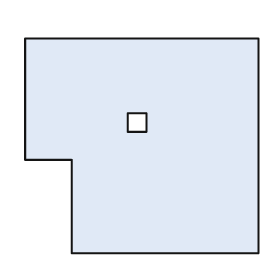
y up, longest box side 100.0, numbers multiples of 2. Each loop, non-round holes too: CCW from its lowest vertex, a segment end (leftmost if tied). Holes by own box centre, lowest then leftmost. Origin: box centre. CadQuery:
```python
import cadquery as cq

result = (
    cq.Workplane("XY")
    .moveTo(-30.0, -46.0)
    .lineTo(50.0, -46.0)
    .lineTo(50.0, 46.0)
    .lineTo(-50.0, 46.0)
    .lineTo(-50.0, -6.0)
    .lineTo(-30.0, -6.0)
    .close()
    .moveTo(-6.0, 6.0)
    .lineTo(2.0, 6.0)
    .lineTo(2.0, 14.0)
    .lineTo(-6.0, 14.0)
    .close()
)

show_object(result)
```